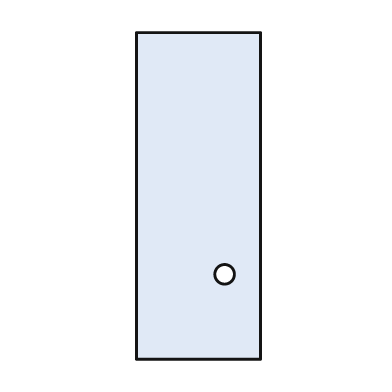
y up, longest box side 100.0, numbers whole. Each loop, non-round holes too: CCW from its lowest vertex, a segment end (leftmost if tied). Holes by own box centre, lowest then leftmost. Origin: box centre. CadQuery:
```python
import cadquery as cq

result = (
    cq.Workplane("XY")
    .moveTo(-19.0, -50.0)
    .lineTo(19.0, -50.0)
    .lineTo(19.0, 50.0)
    .lineTo(-19.0, 50.0)
    .close()
    .moveTo(8.0, -24.0)
    .circle(3.0)
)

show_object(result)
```